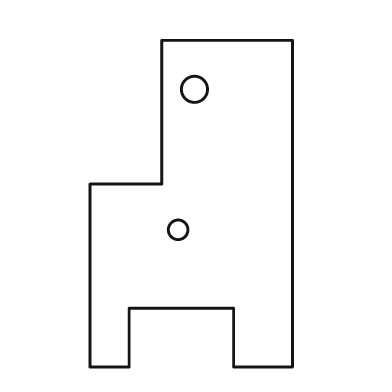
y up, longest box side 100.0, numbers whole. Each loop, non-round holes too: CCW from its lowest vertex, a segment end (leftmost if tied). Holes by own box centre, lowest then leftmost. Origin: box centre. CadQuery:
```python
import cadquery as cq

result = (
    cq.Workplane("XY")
    .moveTo(-31.0, -50.0)
    .lineTo(-19.0, -50.0)
    .lineTo(-19.0, -32.0)
    .lineTo(13.0, -32.0)
    .lineTo(13.0, -50.0)
    .lineTo(31.0, -50.0)
    .lineTo(31.0, 50.0)
    .lineTo(-9.0, 50.0)
    .lineTo(-9.0, 6.0)
    .lineTo(-31.0, 6.0)
    .close()
    .moveTo(-4.0, -8.0)
    .circle(3.0)
    .moveTo(1.0, 35.0)
    .circle(4.0)
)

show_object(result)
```